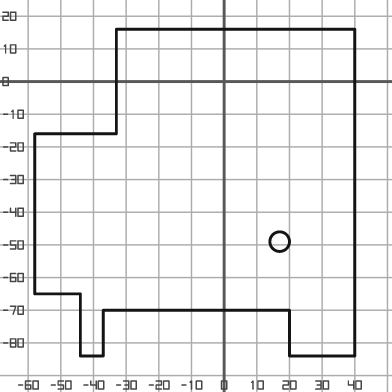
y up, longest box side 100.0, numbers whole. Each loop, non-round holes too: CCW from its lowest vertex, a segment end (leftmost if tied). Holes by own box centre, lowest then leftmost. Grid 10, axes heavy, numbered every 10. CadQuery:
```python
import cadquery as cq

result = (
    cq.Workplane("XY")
    .moveTo(-44.0, -84.0)
    .lineTo(-37.0, -84.0)
    .lineTo(-37.0, -70.0)
    .lineTo(20.0, -70.0)
    .lineTo(20.0, -84.0)
    .lineTo(40.0, -84.0)
    .lineTo(40.0, 16.0)
    .lineTo(-33.0, 16.0)
    .lineTo(-33.0, -16.0)
    .lineTo(-58.0, -16.0)
    .lineTo(-58.0, -65.0)
    .lineTo(-44.0, -65.0)
    .close()
    .moveTo(17.0, -49.0)
    .circle(3.0)
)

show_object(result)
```